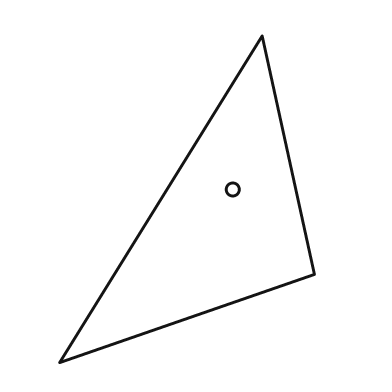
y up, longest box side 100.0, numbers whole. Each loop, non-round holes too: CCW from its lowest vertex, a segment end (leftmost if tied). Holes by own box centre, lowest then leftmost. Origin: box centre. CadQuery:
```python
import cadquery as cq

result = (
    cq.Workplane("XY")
    .moveTo(-39.0, -50.0)
    .lineTo(39.0, -23.0)
    .lineTo(23.0, 50.0)
    .close()
    .moveTo(14.0, 3.0)
    .circle(2.0)
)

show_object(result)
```